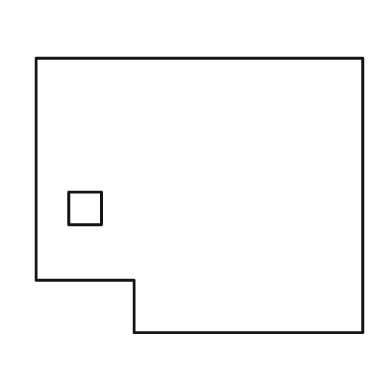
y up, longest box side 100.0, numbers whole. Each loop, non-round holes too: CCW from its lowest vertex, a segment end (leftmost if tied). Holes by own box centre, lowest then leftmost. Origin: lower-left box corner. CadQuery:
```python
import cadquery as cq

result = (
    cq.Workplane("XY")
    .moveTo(30.0, 0.0)
    .lineTo(100.0, 0.0)
    .lineTo(100.0, 84.0)
    .lineTo(0.0, 84.0)
    .lineTo(0.0, 16.0)
    .lineTo(30.0, 16.0)
    .close()
    .moveTo(10.0, 33.0)
    .lineTo(20.0, 33.0)
    .lineTo(20.0, 43.0)
    .lineTo(10.0, 43.0)
    .close()
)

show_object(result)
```